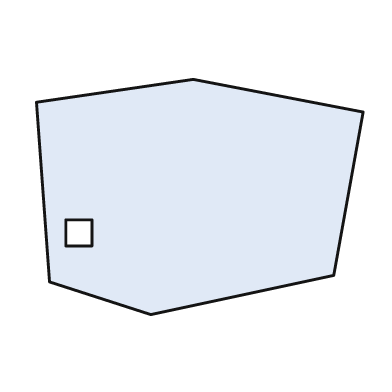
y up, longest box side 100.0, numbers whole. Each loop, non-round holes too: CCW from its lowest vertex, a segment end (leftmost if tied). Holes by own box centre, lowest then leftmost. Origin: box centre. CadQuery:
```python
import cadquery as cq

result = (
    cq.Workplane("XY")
    .moveTo(-15.0, -36.0)
    .lineTo(41.0, -24.0)
    .lineTo(50.0, 26.0)
    .lineTo(-2.0, 36.0)
    .lineTo(-50.0, 29.0)
    .lineTo(-46.0, -26.0)
    .close()
    .moveTo(-41.0, -15.0)
    .lineTo(-33.0, -15.0)
    .lineTo(-33.0, -7.0)
    .lineTo(-41.0, -7.0)
    .close()
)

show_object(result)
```